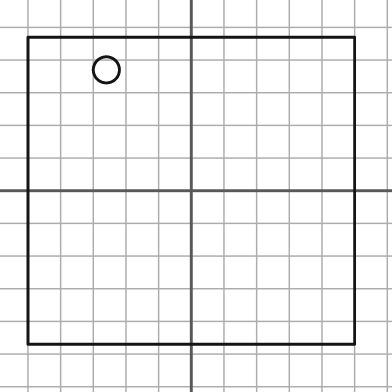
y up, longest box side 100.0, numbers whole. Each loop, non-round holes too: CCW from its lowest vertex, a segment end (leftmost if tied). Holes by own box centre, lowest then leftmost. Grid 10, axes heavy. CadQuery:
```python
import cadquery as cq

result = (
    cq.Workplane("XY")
    .moveTo(-50.0, -47.0)
    .lineTo(50.0, -47.0)
    .lineTo(50.0, 47.0)
    .lineTo(-50.0, 47.0)
    .close()
    .moveTo(-26.0, 37.0)
    .circle(4.0)
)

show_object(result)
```